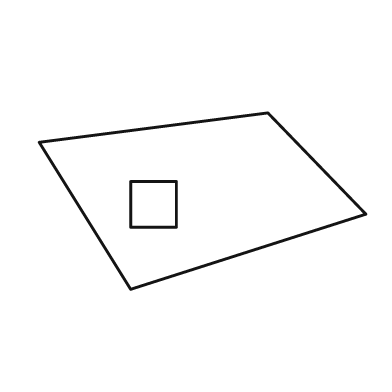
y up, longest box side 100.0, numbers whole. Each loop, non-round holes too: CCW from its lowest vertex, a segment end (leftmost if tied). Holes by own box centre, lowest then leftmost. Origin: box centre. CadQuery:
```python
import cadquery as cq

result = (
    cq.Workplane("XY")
    .moveTo(-22.0, -27.0)
    .lineTo(50.0, -4.0)
    .lineTo(20.0, 27.0)
    .lineTo(-50.0, 18.0)
    .close()
    .moveTo(-22.0, -8.0)
    .lineTo(-8.0, -8.0)
    .lineTo(-8.0, 6.0)
    .lineTo(-22.0, 6.0)
    .close()
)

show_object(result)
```